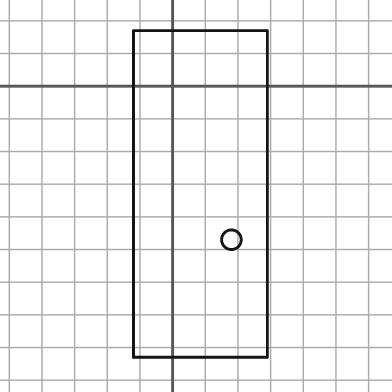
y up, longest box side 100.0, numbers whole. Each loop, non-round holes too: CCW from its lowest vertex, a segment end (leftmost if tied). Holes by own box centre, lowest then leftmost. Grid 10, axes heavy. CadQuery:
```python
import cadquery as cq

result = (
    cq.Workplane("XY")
    .moveTo(-12.0, -83.0)
    .lineTo(29.0, -83.0)
    .lineTo(29.0, 17.0)
    .lineTo(-12.0, 17.0)
    .close()
    .moveTo(18.0, -47.0)
    .circle(3.0)
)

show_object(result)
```